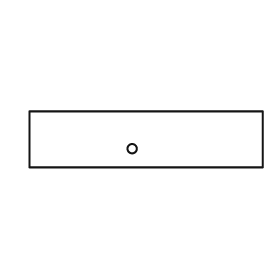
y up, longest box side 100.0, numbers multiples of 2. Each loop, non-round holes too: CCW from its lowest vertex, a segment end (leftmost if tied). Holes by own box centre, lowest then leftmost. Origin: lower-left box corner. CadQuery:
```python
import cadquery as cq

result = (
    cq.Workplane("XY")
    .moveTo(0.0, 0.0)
    .lineTo(100.0, 0.0)
    .lineTo(100.0, 24.0)
    .lineTo(0.0, 24.0)
    .close()
    .moveTo(44.0, 8.0)
    .circle(2.0)
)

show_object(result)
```